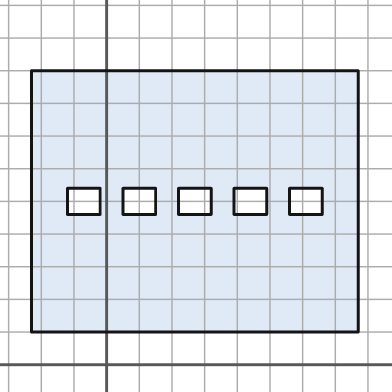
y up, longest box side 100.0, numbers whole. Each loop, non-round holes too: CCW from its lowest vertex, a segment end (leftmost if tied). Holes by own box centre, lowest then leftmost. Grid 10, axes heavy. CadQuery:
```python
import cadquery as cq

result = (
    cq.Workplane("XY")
    .moveTo(-23.0, 10.0)
    .lineTo(77.0, 10.0)
    .lineTo(77.0, 90.0)
    .lineTo(-23.0, 90.0)
    .close()
    .moveTo(-12.0, 46.0)
    .lineTo(-2.0, 46.0)
    .lineTo(-2.0, 54.0)
    .lineTo(-12.0, 54.0)
    .close()
    .moveTo(5.0, 46.0)
    .lineTo(15.0, 46.0)
    .lineTo(15.0, 54.0)
    .lineTo(5.0, 54.0)
    .close()
    .moveTo(22.0, 46.0)
    .lineTo(32.0, 46.0)
    .lineTo(32.0, 54.0)
    .lineTo(22.0, 54.0)
    .close()
    .moveTo(39.0, 46.0)
    .lineTo(49.0, 46.0)
    .lineTo(49.0, 54.0)
    .lineTo(39.0, 54.0)
    .close()
    .moveTo(56.0, 46.0)
    .lineTo(66.0, 46.0)
    .lineTo(66.0, 54.0)
    .lineTo(56.0, 54.0)
    .close()
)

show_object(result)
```